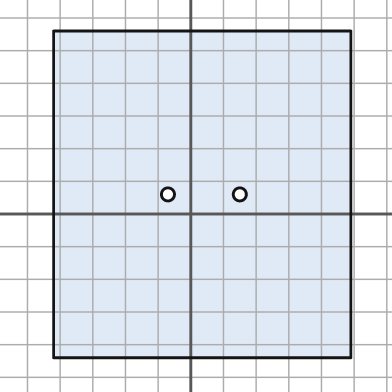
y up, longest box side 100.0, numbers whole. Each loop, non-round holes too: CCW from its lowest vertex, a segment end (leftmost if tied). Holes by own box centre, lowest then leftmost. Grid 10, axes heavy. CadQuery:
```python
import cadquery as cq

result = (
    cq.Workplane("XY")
    .moveTo(-42.0, -44.0)
    .lineTo(49.0, -44.0)
    .lineTo(49.0, 56.0)
    .lineTo(-42.0, 56.0)
    .close()
    .moveTo(-7.0, 6.0)
    .circle(2.0)
    .moveTo(15.0, 6.0)
    .circle(2.0)
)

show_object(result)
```